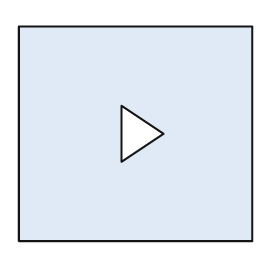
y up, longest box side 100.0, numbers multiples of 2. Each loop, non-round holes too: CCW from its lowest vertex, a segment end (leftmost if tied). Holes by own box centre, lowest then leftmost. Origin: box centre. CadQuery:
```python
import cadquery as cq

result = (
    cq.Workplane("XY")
    .moveTo(-50.0, -46.0)
    .lineTo(50.0, -46.0)
    .lineTo(50.0, 46.0)
    .lineTo(-50.0, 46.0)
    .close()
    .moveTo(-6.0, -12.0)
    .lineTo(12.0, 0.0)
    .lineTo(-6.0, 12.0)
    .close()
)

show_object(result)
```